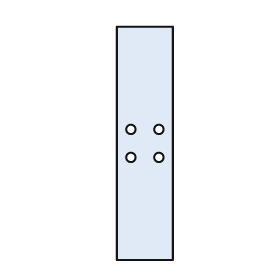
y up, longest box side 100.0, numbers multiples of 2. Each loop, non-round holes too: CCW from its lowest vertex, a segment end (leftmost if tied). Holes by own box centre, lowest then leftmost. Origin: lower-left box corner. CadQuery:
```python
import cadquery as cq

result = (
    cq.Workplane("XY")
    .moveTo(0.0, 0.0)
    .lineTo(24.0, 0.0)
    .lineTo(24.0, 100.0)
    .lineTo(0.0, 100.0)
    .close()
    .moveTo(6.0, 44.0)
    .circle(2.0)
    .moveTo(18.0, 44.0)
    .circle(2.0)
    .moveTo(6.0, 56.0)
    .circle(2.0)
    .moveTo(18.0, 56.0)
    .circle(2.0)
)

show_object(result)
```